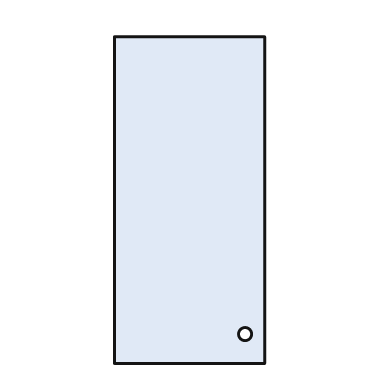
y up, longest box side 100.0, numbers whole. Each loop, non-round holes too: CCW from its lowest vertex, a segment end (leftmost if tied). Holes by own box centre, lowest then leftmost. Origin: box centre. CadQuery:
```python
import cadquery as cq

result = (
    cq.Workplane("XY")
    .moveTo(-23.0, -50.0)
    .lineTo(23.0, -50.0)
    .lineTo(23.0, 50.0)
    .lineTo(-23.0, 50.0)
    .close()
    .moveTo(17.0, -41.0)
    .circle(2.0)
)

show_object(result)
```